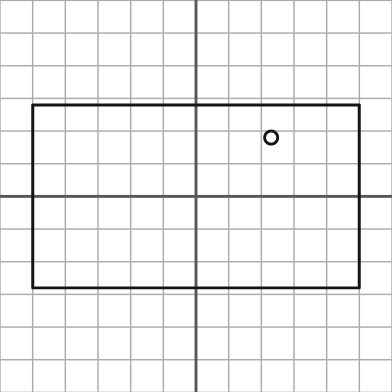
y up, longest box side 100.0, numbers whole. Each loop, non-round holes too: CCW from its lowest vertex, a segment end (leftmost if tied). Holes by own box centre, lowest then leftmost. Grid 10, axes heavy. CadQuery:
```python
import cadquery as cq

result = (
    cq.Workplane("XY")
    .moveTo(-50.0, -28.0)
    .lineTo(50.0, -28.0)
    .lineTo(50.0, 28.0)
    .lineTo(-50.0, 28.0)
    .close()
    .moveTo(23.0, 18.0)
    .circle(2.0)
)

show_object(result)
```